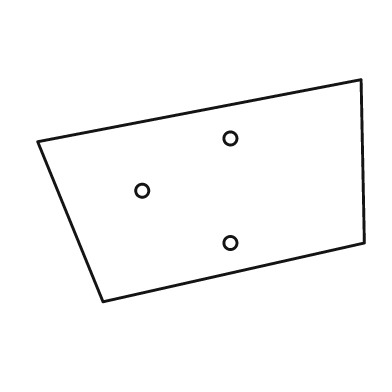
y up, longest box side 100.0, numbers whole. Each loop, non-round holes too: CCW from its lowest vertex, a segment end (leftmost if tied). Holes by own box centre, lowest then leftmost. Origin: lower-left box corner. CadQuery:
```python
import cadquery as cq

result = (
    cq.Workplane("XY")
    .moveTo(20.0, 0.0)
    .lineTo(100.0, 18.0)
    .lineTo(99.0, 68.0)
    .lineTo(0.0, 49.0)
    .close()
    .moveTo(59.0, 18.0)
    .circle(2.0)
    .moveTo(32.0, 34.0)
    .circle(2.0)
    .moveTo(59.0, 50.0)
    .circle(2.0)
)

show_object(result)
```